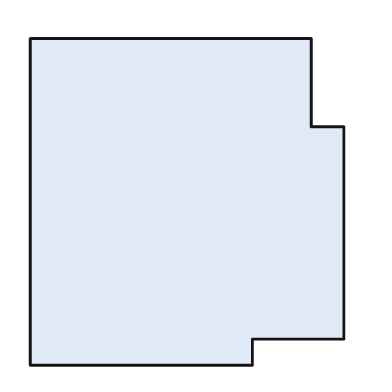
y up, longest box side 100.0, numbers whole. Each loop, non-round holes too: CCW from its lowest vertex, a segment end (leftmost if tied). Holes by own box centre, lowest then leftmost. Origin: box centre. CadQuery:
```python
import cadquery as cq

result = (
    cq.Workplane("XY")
    .moveTo(-48.0, -50.0)
    .lineTo(20.0, -50.0)
    .lineTo(20.0, -42.0)
    .lineTo(48.0, -42.0)
    .lineTo(48.0, 23.0)
    .lineTo(38.0, 23.0)
    .lineTo(38.0, 50.0)
    .lineTo(-48.0, 50.0)
    .close()
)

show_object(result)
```